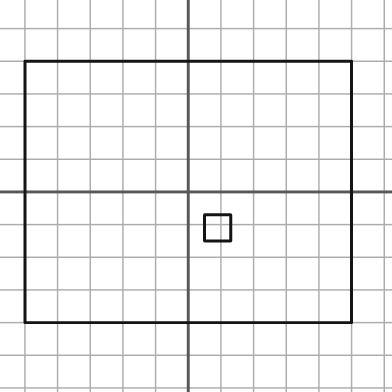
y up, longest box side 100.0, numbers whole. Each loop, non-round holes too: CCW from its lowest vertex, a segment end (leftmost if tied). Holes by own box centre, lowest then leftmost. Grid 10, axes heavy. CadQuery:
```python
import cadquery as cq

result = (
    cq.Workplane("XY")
    .moveTo(-50.0, -40.0)
    .lineTo(50.0, -40.0)
    .lineTo(50.0, 40.0)
    .lineTo(-50.0, 40.0)
    .close()
    .moveTo(5.0, -15.0)
    .lineTo(13.0, -15.0)
    .lineTo(13.0, -7.0)
    .lineTo(5.0, -7.0)
    .close()
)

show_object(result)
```